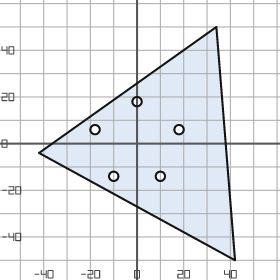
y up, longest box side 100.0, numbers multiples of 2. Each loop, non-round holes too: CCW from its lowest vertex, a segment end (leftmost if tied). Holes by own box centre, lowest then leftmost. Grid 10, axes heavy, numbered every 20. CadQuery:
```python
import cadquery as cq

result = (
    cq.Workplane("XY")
    .moveTo(42.0, -50.0)
    .lineTo(34.0, 50.0)
    .lineTo(-42.0, -4.0)
    .close()
    .moveTo(-10.0, -14.0)
    .circle(2.0)
    .moveTo(10.0, -14.0)
    .circle(2.0)
    .moveTo(-18.0, 6.0)
    .circle(2.0)
    .moveTo(18.0, 6.0)
    .circle(2.0)
    .moveTo(0.0, 18.0)
    .circle(2.0)
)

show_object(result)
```